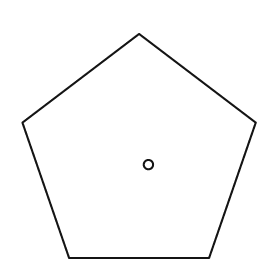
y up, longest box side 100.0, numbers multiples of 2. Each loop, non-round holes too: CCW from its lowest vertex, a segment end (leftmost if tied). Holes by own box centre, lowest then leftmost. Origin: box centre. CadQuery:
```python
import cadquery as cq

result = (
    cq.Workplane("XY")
    .moveTo(-30.0, -48.0)
    .lineTo(30.0, -48.0)
    .lineTo(50.0, 10.0)
    .lineTo(0.0, 48.0)
    .lineTo(-50.0, 10.0)
    .close()
    .moveTo(4.0, -8.0)
    .circle(2.0)
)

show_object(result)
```